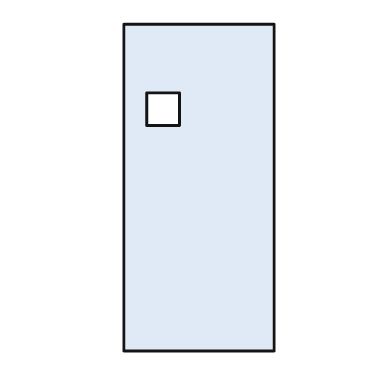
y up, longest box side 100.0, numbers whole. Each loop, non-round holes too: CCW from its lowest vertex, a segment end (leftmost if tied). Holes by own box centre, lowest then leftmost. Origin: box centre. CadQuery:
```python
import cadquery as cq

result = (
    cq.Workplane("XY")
    .moveTo(-23.0, -50.0)
    .lineTo(23.0, -50.0)
    .lineTo(23.0, 50.0)
    .lineTo(-23.0, 50.0)
    .close()
    .moveTo(-16.0, 19.0)
    .lineTo(-6.0, 19.0)
    .lineTo(-6.0, 29.0)
    .lineTo(-16.0, 29.0)
    .close()
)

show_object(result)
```